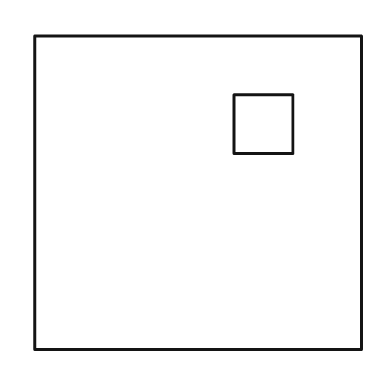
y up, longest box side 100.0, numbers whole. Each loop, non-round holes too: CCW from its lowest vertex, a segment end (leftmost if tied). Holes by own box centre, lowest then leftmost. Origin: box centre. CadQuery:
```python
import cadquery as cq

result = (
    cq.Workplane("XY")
    .moveTo(-50.0, -48.0)
    .lineTo(50.0, -48.0)
    .lineTo(50.0, 48.0)
    .lineTo(-50.0, 48.0)
    .close()
    .moveTo(11.0, 12.0)
    .lineTo(29.0, 12.0)
    .lineTo(29.0, 30.0)
    .lineTo(11.0, 30.0)
    .close()
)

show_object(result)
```